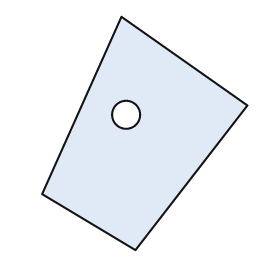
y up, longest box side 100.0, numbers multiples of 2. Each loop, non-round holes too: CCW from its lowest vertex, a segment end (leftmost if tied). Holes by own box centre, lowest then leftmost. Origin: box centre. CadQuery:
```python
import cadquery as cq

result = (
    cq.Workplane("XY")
    .moveTo(-4.0, -50.0)
    .lineTo(44.0, 12.0)
    .lineTo(-10.0, 50.0)
    .lineTo(-44.0, -26.0)
    .close()
    .moveTo(-8.0, 8.0)
    .circle(6.0)
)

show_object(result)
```